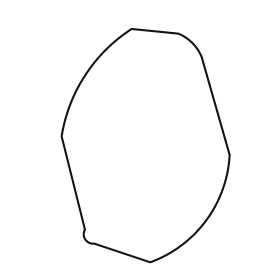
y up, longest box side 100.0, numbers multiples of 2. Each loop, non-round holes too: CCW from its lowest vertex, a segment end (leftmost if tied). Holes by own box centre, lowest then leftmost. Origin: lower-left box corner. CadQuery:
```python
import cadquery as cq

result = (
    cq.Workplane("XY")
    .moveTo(38.0, 0.0)
    .threePointArc((62.0, 18.0), (72.0, 46.0))
    .lineTo(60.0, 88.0)
    .threePointArc((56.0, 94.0), (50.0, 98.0))
    .lineTo(30.0, 100.0)
    .threePointArc((10.0, 80.0), (0.0, 54.0))
    .lineTo(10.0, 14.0)
    .threePointArc((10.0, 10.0), (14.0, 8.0))
    .close()
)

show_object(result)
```